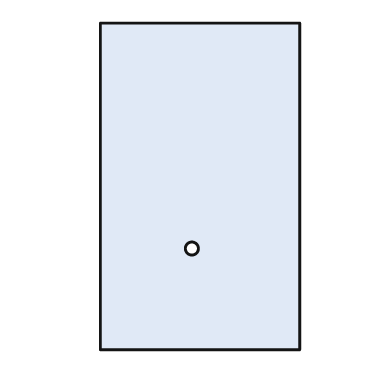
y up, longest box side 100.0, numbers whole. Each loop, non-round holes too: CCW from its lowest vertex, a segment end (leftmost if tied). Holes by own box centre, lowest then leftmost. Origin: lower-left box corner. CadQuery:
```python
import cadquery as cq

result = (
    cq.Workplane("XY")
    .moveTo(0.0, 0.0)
    .lineTo(61.0, 0.0)
    .lineTo(61.0, 100.0)
    .lineTo(0.0, 100.0)
    .close()
    .moveTo(28.0, 31.0)
    .circle(2.0)
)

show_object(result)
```